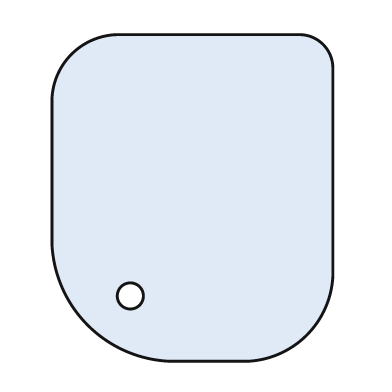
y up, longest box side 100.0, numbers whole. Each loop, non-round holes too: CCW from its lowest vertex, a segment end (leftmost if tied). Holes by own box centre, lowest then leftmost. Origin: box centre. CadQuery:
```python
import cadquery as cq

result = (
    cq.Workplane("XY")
    .moveTo(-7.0, -50.0)
    .lineTo(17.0, -50.0)
    .threePointArc((35.0, -42.0), (43.0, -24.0))
    .lineTo(43.0, 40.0)
    .threePointArc((40.0, 47.0), (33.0, 50.0))
    .lineTo(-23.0, 50.0)
    .threePointArc((-37.0, 44.0), (-43.0, 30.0))
    .lineTo(-43.0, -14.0)
    .threePointArc((-32.0, -39.0), (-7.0, -50.0))
    .close()
    .moveTo(-19.0, -30.0)
    .circle(4.0)
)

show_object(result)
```